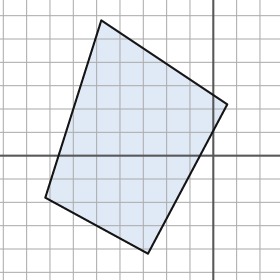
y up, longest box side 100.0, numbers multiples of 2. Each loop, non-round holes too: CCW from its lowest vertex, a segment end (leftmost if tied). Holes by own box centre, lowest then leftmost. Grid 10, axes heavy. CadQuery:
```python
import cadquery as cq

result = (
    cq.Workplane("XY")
    .moveTo(-28.0, -42.0)
    .lineTo(6.0, 22.0)
    .lineTo(-48.0, 58.0)
    .lineTo(-72.0, -18.0)
    .close()
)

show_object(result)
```